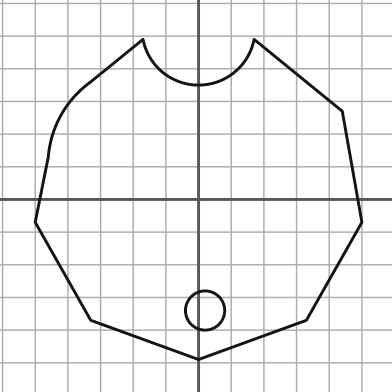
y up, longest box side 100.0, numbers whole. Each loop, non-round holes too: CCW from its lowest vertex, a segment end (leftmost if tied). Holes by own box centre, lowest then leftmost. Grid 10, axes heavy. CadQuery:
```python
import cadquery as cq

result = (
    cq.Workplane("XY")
    .moveTo(0.0, -49.0)
    .lineTo(33.0, -37.0)
    .lineTo(50.0, -7.0)
    .lineTo(44.0, 27.0)
    .lineTo(17.0, 49.0)
    .threePointArc((0.0, 35.0), (-17.0, 49.0))
    .lineTo(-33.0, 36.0)
    .threePointArc((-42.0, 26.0), (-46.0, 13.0))
    .lineTo(-50.0, -7.0)
    .lineTo(-33.0, -37.0)
    .close()
    .moveTo(2.0, -34.0)
    .circle(6.0)
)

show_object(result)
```